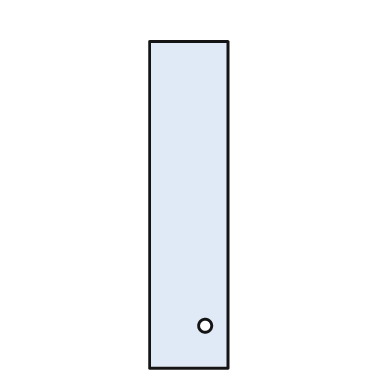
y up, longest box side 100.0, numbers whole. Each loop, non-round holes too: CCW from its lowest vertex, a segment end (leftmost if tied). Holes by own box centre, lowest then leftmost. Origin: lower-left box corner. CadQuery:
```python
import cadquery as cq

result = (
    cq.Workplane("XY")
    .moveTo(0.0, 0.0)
    .lineTo(24.0, 0.0)
    .lineTo(24.0, 100.0)
    .lineTo(0.0, 100.0)
    .close()
    .moveTo(17.0, 13.0)
    .circle(2.0)
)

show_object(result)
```